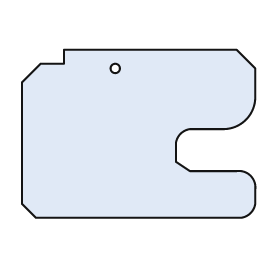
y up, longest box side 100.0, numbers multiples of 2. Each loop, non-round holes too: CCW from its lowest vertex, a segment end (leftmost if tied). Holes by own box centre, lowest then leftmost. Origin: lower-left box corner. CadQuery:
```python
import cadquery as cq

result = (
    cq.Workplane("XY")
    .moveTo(6.0, 0.0)
    .lineTo(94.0, 0.0)
    .threePointArc((98.0, 2.0), (100.0, 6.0))
    .lineTo(100.0, 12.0)
    .threePointArc((98.0, 18.0), (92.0, 20.0))
    .lineTo(72.0, 20.0)
    .lineTo(66.0, 24.0)
    .lineTo(66.0, 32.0)
    .threePointArc((68.0, 36.0), (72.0, 38.0))
    .lineTo(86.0, 38.0)
    .threePointArc((96.0, 42.0), (100.0, 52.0))
    .lineTo(100.0, 64.0)
    .lineTo(92.0, 72.0)
    .lineTo(18.0, 72.0)
    .lineTo(18.0, 66.0)
    .lineTo(8.0, 66.0)
    .lineTo(0.0, 58.0)
    .lineTo(0.0, 6.0)
    .close()
    .moveTo(40.0, 64.0)
    .circle(2.0)
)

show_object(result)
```